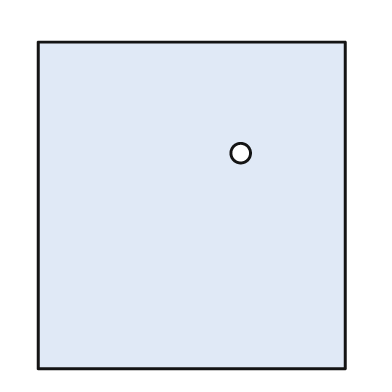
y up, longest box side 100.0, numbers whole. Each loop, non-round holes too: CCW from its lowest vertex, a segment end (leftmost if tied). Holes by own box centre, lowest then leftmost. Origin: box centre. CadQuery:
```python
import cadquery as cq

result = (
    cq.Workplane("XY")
    .moveTo(-47.0, -50.0)
    .lineTo(47.0, -50.0)
    .lineTo(47.0, 50.0)
    .lineTo(-47.0, 50.0)
    .close()
    .moveTo(15.0, 16.0)
    .circle(3.0)
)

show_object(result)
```